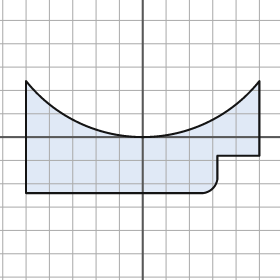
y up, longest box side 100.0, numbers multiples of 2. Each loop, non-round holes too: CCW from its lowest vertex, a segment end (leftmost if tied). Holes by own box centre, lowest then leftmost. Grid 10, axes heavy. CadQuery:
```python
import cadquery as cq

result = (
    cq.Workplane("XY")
    .moveTo(-50.0, -24.0)
    .lineTo(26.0, -24.0)
    .threePointArc((30.0, -22.0), (32.0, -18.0))
    .lineTo(32.0, -8.0)
    .lineTo(50.0, -8.0)
    .lineTo(50.0, 24.0)
    .threePointArc((0.0, 0.0), (-50.0, 24.0))
    .close()
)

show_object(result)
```